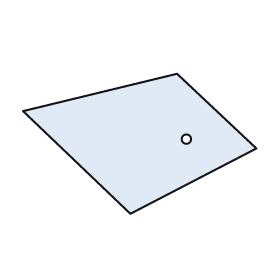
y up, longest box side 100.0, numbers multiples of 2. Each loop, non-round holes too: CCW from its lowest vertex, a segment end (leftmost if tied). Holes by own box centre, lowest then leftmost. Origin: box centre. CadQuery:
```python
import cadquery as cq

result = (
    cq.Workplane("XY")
    .moveTo(-4.0, -30.0)
    .lineTo(50.0, -2.0)
    .lineTo(16.0, 30.0)
    .lineTo(-50.0, 14.0)
    .close()
    .moveTo(20.0, 2.0)
    .circle(2.0)
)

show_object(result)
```